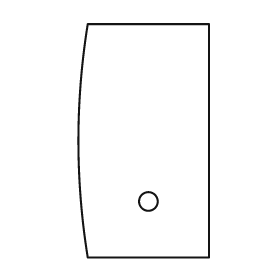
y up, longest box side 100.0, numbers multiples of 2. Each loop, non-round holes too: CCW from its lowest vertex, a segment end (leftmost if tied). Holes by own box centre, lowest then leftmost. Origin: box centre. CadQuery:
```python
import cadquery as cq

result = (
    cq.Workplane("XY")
    .moveTo(-24.0, -50.0)
    .lineTo(28.0, -50.0)
    .lineTo(28.0, 50.0)
    .lineTo(-24.0, 50.0)
    .threePointArc((-28.0, 0.0), (-24.0, -50.0))
    .close()
    .moveTo(2.0, -26.0)
    .circle(4.0)
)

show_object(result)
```